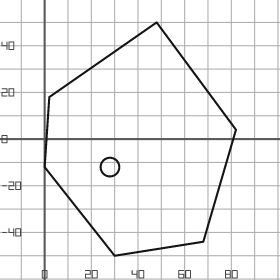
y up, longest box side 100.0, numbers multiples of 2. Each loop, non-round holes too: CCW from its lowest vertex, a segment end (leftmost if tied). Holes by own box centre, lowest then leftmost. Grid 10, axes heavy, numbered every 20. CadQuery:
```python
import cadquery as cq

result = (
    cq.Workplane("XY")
    .moveTo(30.0, -50.0)
    .lineTo(68.0, -44.0)
    .lineTo(82.0, 4.0)
    .lineTo(48.0, 50.0)
    .lineTo(2.0, 18.0)
    .lineTo(0.0, -12.0)
    .close()
    .moveTo(28.0, -12.0)
    .circle(4.0)
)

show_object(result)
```